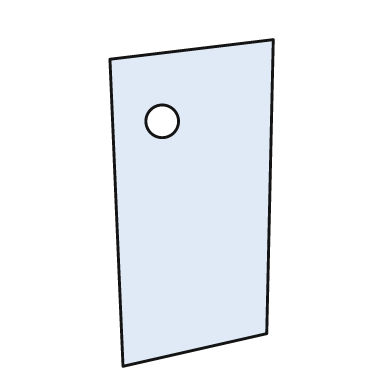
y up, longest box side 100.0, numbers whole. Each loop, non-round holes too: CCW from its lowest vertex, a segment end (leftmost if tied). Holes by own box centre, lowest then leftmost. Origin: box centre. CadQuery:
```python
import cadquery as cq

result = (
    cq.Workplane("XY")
    .moveTo(-21.0, -50.0)
    .lineTo(23.0, -40.0)
    .lineTo(25.0, 50.0)
    .lineTo(-25.0, 44.0)
    .close()
    .moveTo(-9.0, 25.0)
    .circle(5.0)
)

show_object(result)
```